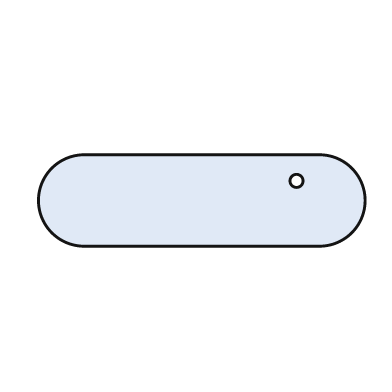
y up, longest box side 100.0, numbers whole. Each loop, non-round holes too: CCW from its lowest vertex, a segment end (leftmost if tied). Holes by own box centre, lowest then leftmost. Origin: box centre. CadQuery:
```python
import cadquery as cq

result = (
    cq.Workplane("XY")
    .moveTo(-36.0, -14.0)
    .lineTo(36.0, -14.0)
    .threePointArc((50.0, 0.0), (36.0, 14.0))
    .lineTo(-36.0, 14.0)
    .threePointArc((-50.0, 0.0), (-36.0, -14.0))
    .close()
    .moveTo(29.0, 6.0)
    .circle(2.0)
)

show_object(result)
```